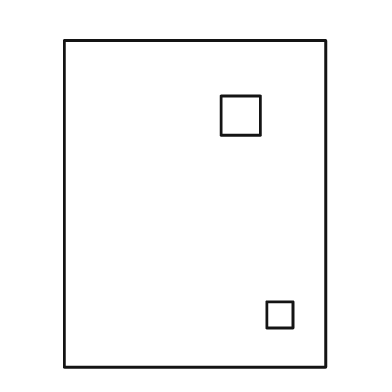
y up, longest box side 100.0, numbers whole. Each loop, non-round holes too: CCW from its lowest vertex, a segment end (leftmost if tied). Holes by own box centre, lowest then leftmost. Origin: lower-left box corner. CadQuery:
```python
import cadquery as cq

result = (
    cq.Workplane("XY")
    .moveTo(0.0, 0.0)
    .lineTo(80.0, 0.0)
    .lineTo(80.0, 100.0)
    .lineTo(0.0, 100.0)
    .close()
    .moveTo(62.0, 12.0)
    .lineTo(70.0, 12.0)
    .lineTo(70.0, 20.0)
    .lineTo(62.0, 20.0)
    .close()
    .moveTo(48.0, 71.0)
    .lineTo(60.0, 71.0)
    .lineTo(60.0, 83.0)
    .lineTo(48.0, 83.0)
    .close()
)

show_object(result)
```